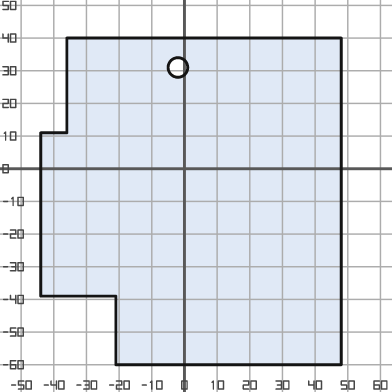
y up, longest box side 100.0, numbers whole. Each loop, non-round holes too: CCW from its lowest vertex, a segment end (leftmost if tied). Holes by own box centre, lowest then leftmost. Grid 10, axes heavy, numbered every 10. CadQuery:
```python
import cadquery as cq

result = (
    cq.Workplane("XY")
    .moveTo(-21.0, -60.0)
    .lineTo(48.0, -60.0)
    .lineTo(48.0, 40.0)
    .lineTo(-36.0, 40.0)
    .lineTo(-36.0, 11.0)
    .lineTo(-44.0, 11.0)
    .lineTo(-44.0, -39.0)
    .lineTo(-21.0, -39.0)
    .close()
    .moveTo(-2.0, 31.0)
    .circle(3.0)
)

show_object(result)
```